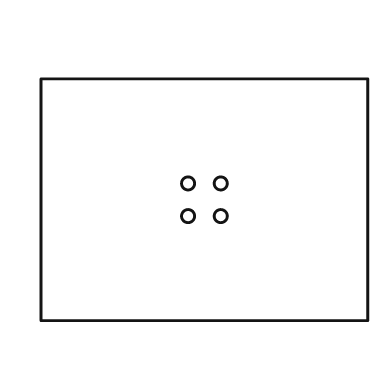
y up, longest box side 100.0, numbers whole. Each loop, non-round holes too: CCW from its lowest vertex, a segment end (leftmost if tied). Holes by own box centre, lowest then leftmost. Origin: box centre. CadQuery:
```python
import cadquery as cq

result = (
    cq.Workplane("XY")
    .moveTo(-50.0, -37.0)
    .lineTo(50.0, -37.0)
    .lineTo(50.0, 37.0)
    .lineTo(-50.0, 37.0)
    .close()
    .moveTo(-5.0, -5.0)
    .circle(2.0)
    .moveTo(5.0, -5.0)
    .circle(2.0)
    .moveTo(-5.0, 5.0)
    .circle(2.0)
    .moveTo(5.0, 5.0)
    .circle(2.0)
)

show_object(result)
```